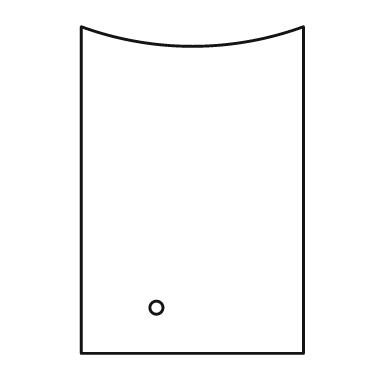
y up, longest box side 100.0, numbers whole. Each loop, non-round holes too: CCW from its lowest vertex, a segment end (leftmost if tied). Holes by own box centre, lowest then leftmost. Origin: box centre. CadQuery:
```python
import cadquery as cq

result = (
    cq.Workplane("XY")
    .moveTo(-34.0, -50.0)
    .lineTo(34.0, -50.0)
    .lineTo(34.0, 50.0)
    .threePointArc((0.0, 44.0), (-34.0, 50.0))
    .close()
    .moveTo(-11.0, -36.0)
    .circle(2.0)
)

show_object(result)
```